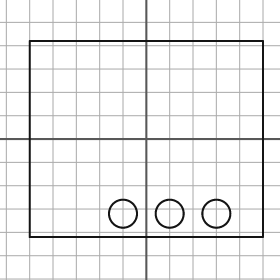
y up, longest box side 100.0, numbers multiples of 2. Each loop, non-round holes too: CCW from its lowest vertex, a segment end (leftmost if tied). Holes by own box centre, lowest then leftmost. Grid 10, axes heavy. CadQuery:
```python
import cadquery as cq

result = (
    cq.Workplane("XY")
    .moveTo(-50.0, -42.0)
    .lineTo(50.0, -42.0)
    .lineTo(50.0, 42.0)
    .lineTo(-50.0, 42.0)
    .close()
    .moveTo(-10.0, -32.0)
    .circle(6.0)
    .moveTo(10.0, -32.0)
    .circle(6.0)
    .moveTo(30.0, -32.0)
    .circle(6.0)
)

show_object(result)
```